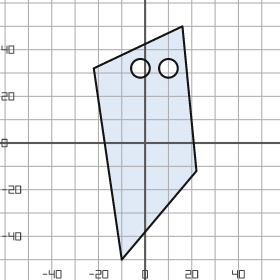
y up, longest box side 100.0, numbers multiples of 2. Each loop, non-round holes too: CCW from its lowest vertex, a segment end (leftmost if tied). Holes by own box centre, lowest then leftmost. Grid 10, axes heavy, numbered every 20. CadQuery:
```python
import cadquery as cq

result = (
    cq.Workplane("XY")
    .moveTo(-10.0, -50.0)
    .lineTo(22.0, -12.0)
    .lineTo(16.0, 50.0)
    .lineTo(-22.0, 32.0)
    .close()
    .moveTo(-2.0, 32.0)
    .circle(4.0)
    .moveTo(10.0, 32.0)
    .circle(4.0)
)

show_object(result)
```